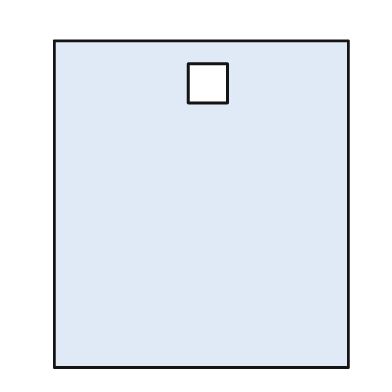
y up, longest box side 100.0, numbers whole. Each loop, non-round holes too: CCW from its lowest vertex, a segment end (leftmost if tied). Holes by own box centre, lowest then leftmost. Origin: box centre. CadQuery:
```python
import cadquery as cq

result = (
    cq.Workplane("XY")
    .moveTo(-45.0, -50.0)
    .lineTo(45.0, -50.0)
    .lineTo(45.0, 50.0)
    .lineTo(-45.0, 50.0)
    .close()
    .moveTo(-4.0, 31.0)
    .lineTo(8.0, 31.0)
    .lineTo(8.0, 43.0)
    .lineTo(-4.0, 43.0)
    .close()
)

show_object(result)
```